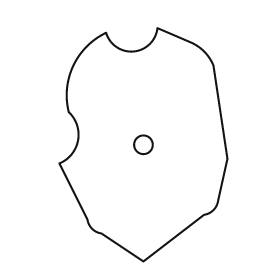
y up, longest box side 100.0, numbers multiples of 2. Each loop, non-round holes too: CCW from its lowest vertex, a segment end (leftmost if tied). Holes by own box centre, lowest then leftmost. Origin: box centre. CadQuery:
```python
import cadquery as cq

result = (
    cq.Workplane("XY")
    .moveTo(0.0, -50.0)
    .lineTo(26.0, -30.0)
    .threePointArc((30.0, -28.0), (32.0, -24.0))
    .lineTo(36.0, -6.0)
    .lineTo(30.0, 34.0)
    .threePointArc((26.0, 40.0), (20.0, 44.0))
    .lineTo(6.0, 50.0)
    .threePointArc((-4.0, 40.0), (-16.0, 48.0))
    .threePointArc((-30.0, 34.0), (-32.0, 14.0))
    .threePointArc((-28.0, 2.0), (-36.0, -8.0))
    .lineTo(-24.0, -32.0)
    .threePointArc((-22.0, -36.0), (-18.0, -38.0))
    .close()
    .moveTo(0.0, 0.0)
    .circle(4.0)
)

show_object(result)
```